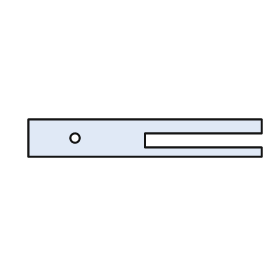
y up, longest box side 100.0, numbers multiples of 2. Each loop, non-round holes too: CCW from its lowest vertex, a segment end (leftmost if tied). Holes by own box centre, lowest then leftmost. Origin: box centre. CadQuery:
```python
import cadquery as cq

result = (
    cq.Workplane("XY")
    .moveTo(-50.0, -8.0)
    .lineTo(50.0, -8.0)
    .lineTo(50.0, -4.0)
    .lineTo(0.0, -4.0)
    .lineTo(0.0, 2.0)
    .lineTo(50.0, 2.0)
    .lineTo(50.0, 8.0)
    .lineTo(-50.0, 8.0)
    .close()
    .moveTo(-30.0, 0.0)
    .circle(2.0)
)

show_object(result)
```